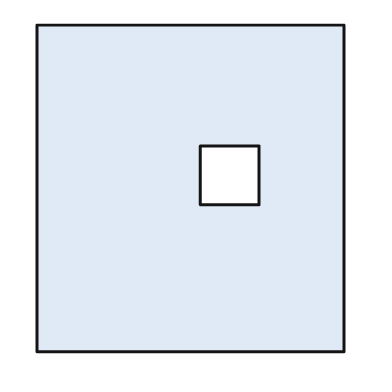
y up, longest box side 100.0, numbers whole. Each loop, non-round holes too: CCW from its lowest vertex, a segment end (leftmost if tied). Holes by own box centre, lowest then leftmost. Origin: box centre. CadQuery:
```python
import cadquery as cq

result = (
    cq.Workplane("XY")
    .moveTo(-47.0, -50.0)
    .lineTo(47.0, -50.0)
    .lineTo(47.0, 50.0)
    .lineTo(-47.0, 50.0)
    .close()
    .moveTo(3.0, -5.0)
    .lineTo(21.0, -5.0)
    .lineTo(21.0, 13.0)
    .lineTo(3.0, 13.0)
    .close()
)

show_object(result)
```